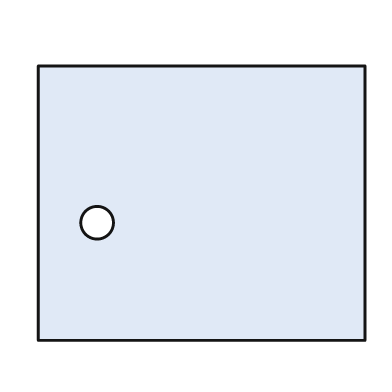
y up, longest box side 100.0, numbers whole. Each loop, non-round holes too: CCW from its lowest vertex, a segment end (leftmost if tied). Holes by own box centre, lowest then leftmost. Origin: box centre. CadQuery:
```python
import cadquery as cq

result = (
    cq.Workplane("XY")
    .moveTo(-50.0, -42.0)
    .lineTo(50.0, -42.0)
    .lineTo(50.0, 42.0)
    .lineTo(-50.0, 42.0)
    .close()
    .moveTo(-32.0, -6.0)
    .circle(5.0)
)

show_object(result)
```